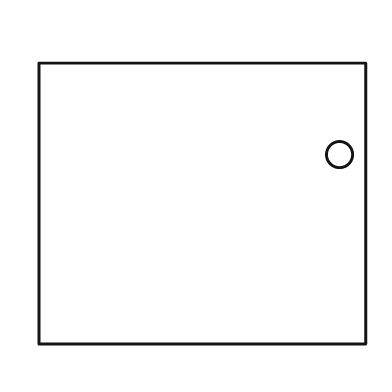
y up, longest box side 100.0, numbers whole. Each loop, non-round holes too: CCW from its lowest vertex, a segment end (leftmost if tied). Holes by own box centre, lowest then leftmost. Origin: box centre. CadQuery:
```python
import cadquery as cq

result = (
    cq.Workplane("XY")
    .moveTo(-50.0, -43.0)
    .lineTo(50.0, -43.0)
    .lineTo(50.0, 43.0)
    .lineTo(-50.0, 43.0)
    .close()
    .moveTo(42.0, 15.0)
    .circle(4.0)
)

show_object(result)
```